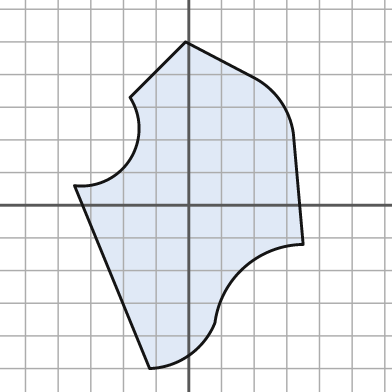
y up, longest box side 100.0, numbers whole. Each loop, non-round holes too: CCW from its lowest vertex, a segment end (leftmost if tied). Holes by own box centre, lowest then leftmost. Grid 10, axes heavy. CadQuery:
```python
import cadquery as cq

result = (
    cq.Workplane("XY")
    .moveTo(-12.0, -50.0)
    .threePointArc((0.0, -46.0), (8.0, -36.0))
    .threePointArc((17.0, -19.0), (35.0, -12.0))
    .lineTo(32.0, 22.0)
    .threePointArc((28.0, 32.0), (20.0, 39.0))
    .lineTo(-1.0, 50.0)
    .lineTo(-18.0, 33.0)
    .threePointArc((-18.0, 14.0), (-35.0, 6.0))
    .close()
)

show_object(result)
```